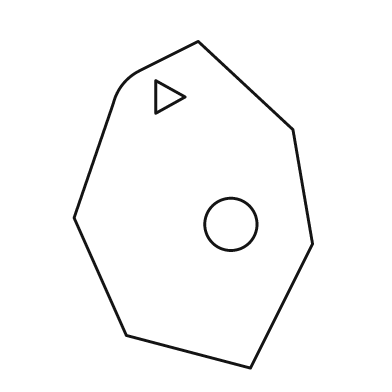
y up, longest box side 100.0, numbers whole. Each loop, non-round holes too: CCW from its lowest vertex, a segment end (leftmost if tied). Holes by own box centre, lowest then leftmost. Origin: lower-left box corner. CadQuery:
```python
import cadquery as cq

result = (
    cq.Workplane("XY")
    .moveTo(54.0, 0.0)
    .lineTo(73.0, 38.0)
    .lineTo(67.0, 73.0)
    .lineTo(38.0, 100.0)
    .lineTo(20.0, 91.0)
    .threePointArc((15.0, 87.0), (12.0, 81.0))
    .lineTo(0.0, 46.0)
    .lineTo(16.0, 10.0)
    .close()
    .moveTo(48.0, 44.0)
    .circle(8.0)
    .moveTo(25.0, 78.0)
    .lineTo(34.0, 83.0)
    .lineTo(25.0, 88.0)
    .close()
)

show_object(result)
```